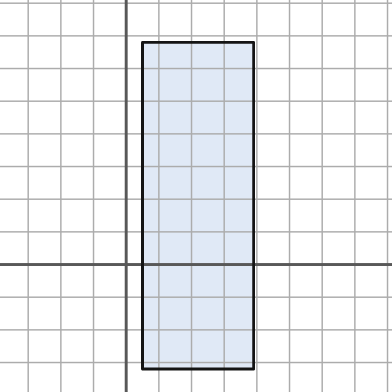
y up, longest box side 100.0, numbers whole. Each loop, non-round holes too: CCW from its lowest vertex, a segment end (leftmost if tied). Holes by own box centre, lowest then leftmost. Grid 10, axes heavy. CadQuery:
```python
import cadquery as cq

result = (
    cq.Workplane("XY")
    .moveTo(5.0, -32.0)
    .lineTo(39.0, -32.0)
    .lineTo(39.0, 68.0)
    .lineTo(5.0, 68.0)
    .close()
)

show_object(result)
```